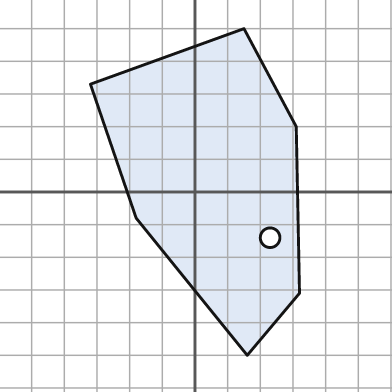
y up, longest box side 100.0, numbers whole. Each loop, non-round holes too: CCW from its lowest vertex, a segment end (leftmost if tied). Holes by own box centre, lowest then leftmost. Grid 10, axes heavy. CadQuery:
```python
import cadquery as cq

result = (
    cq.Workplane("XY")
    .moveTo(16.0, -50.0)
    .lineTo(32.0, -31.0)
    .lineTo(31.0, 20.0)
    .lineTo(15.0, 50.0)
    .lineTo(-32.0, 33.0)
    .lineTo(-18.0, -8.0)
    .close()
    .moveTo(23.0, -14.0)
    .circle(3.0)
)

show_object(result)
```